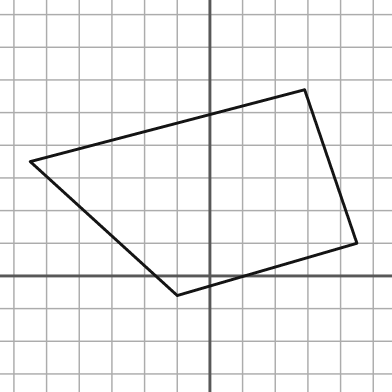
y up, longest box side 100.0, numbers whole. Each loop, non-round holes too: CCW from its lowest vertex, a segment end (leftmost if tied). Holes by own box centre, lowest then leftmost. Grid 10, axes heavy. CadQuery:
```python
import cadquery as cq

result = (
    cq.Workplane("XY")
    .moveTo(-10.0, -6.0)
    .lineTo(45.0, 10.0)
    .lineTo(29.0, 57.0)
    .lineTo(-55.0, 35.0)
    .close()
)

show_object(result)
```